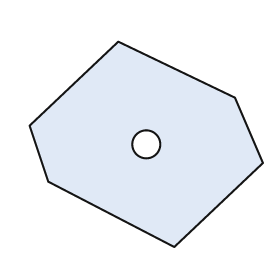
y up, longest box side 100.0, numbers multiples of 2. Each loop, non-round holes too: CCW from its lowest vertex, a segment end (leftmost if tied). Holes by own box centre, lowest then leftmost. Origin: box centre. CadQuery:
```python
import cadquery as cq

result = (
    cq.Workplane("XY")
    .moveTo(12.0, -44.0)
    .lineTo(50.0, -8.0)
    .lineTo(38.0, 20.0)
    .lineTo(-12.0, 44.0)
    .lineTo(-50.0, 8.0)
    .lineTo(-42.0, -16.0)
    .close()
    .moveTo(0.0, 0.0)
    .circle(6.0)
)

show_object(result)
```